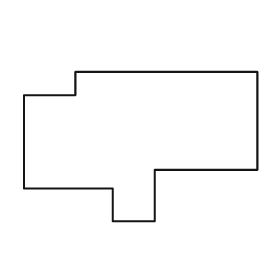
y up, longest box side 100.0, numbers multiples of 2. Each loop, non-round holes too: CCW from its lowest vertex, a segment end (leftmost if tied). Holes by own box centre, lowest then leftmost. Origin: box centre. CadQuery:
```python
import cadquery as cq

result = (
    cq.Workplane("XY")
    .moveTo(-12.0, -32.0)
    .lineTo(6.0, -32.0)
    .lineTo(6.0, -10.0)
    .lineTo(50.0, -10.0)
    .lineTo(50.0, 32.0)
    .lineTo(-28.0, 32.0)
    .lineTo(-28.0, 22.0)
    .lineTo(-50.0, 22.0)
    .lineTo(-50.0, -18.0)
    .lineTo(-12.0, -18.0)
    .close()
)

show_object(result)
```